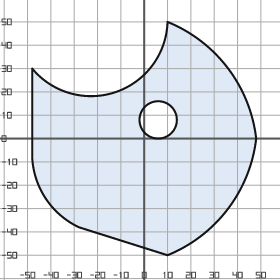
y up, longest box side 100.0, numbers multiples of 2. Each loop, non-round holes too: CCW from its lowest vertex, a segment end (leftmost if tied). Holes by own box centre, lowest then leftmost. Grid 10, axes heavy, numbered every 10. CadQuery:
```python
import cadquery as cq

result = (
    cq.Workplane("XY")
    .moveTo(10.0, -50.0)
    .threePointArc((36.0, -30.0), (48.0, 0.0))
    .threePointArc((36.0, 30.0), (10.0, 50.0))
    .threePointArc((-12.0, 20.0), (-48.0, 30.0))
    .lineTo(-48.0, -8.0)
    .threePointArc((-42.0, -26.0), (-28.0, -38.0))
    .close()
    .moveTo(6.0, 8.0)
    .circle(8.0)
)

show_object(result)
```